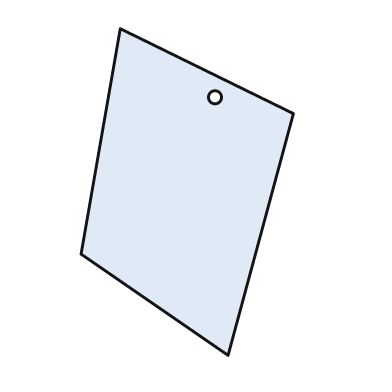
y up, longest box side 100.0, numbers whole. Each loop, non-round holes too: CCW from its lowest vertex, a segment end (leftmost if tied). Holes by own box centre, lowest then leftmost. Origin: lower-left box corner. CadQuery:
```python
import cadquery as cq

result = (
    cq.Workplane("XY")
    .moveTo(45.0, 0.0)
    .lineTo(65.0, 74.0)
    .lineTo(12.0, 100.0)
    .lineTo(0.0, 31.0)
    .close()
    .moveTo(41.0, 79.0)
    .circle(2.0)
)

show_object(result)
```